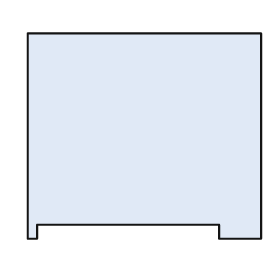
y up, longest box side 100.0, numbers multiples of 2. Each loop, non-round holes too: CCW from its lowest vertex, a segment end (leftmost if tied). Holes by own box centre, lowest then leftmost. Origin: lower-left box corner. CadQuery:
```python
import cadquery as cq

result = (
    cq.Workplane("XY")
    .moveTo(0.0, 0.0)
    .lineTo(4.0, 0.0)
    .lineTo(4.0, 6.0)
    .lineTo(82.0, 6.0)
    .lineTo(82.0, 0.0)
    .lineTo(100.0, 0.0)
    .lineTo(100.0, 88.0)
    .lineTo(0.0, 88.0)
    .close()
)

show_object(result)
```